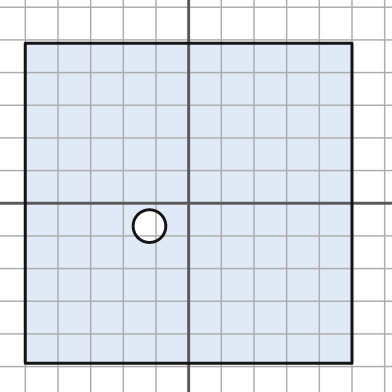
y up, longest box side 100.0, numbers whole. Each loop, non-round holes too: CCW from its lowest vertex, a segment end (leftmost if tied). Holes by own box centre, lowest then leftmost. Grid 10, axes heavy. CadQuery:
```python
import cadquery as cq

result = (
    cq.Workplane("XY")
    .moveTo(-50.0, -49.0)
    .lineTo(50.0, -49.0)
    .lineTo(50.0, 49.0)
    .lineTo(-50.0, 49.0)
    .close()
    .moveTo(-12.0, -7.0)
    .circle(5.0)
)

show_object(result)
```